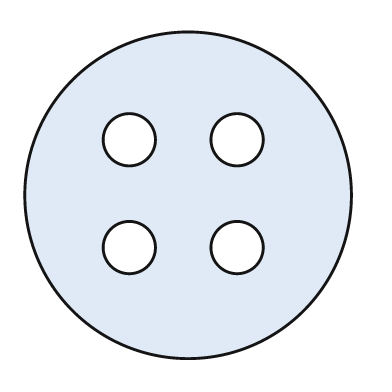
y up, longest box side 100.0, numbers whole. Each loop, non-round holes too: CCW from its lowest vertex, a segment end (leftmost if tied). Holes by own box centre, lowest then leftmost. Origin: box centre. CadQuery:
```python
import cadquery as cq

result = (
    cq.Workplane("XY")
    .moveTo(0.0, 0.0)
    .circle(50.0)
    .moveTo(-18.0, -16.0)
    .circle(8.0)
    .moveTo(15.0, -16.0)
    .circle(8.0)
    .moveTo(-18.0, 17.0)
    .circle(8.0)
    .moveTo(15.0, 17.0)
    .circle(8.0)
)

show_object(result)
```